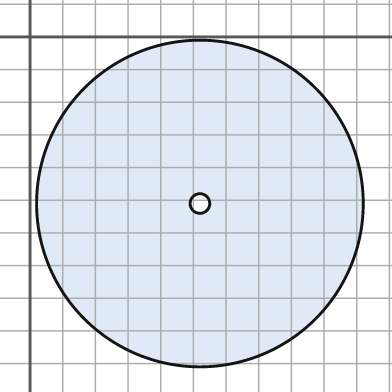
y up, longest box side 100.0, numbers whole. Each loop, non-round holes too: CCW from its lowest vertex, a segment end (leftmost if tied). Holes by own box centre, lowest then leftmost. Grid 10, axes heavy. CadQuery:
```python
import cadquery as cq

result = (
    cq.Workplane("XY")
    .moveTo(52.0, -51.0)
    .circle(50.0)
    .moveTo(52.0, -51.0)
    .circle(3.0)
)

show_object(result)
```